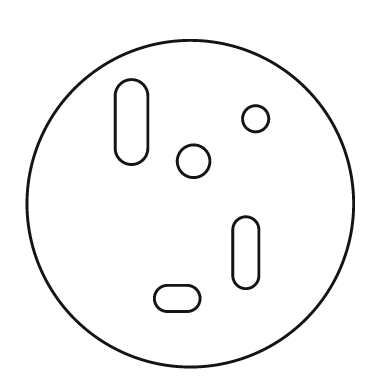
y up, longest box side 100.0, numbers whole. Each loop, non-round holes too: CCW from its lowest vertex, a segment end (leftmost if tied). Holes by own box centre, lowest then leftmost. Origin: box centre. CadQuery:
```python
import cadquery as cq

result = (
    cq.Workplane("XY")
    .moveTo(0.0, 0.0)
    .circle(50.0)
    .moveTo(-7.0, -33.0)
    .lineTo(-1.0, -33.0)
    .threePointArc((3.0, -29.0), (-1.0, -25.0))
    .lineTo(-7.0, -25.0)
    .threePointArc((-11.0, -29.0), (-7.0, -33.0))
    .close()
    .moveTo(13.0, -22.0)
    .threePointArc((17.0, -26.0), (21.0, -22.0))
    .lineTo(21.0, -8.0)
    .threePointArc((17.0, -4.0), (13.0, -8.0))
    .close()
    .moveTo(1.0, 13.0)
    .circle(5.0)
    .moveTo(-23.0, 17.0)
    .threePointArc((-18.0, 12.0), (-13.0, 17.0))
    .lineTo(-13.0, 33.0)
    .threePointArc((-18.0, 38.0), (-23.0, 33.0))
    .close()
    .moveTo(20.0, 26.0)
    .circle(4.0)
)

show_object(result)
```